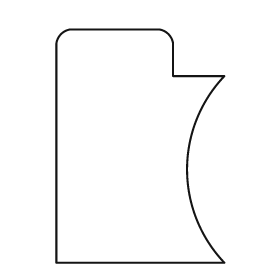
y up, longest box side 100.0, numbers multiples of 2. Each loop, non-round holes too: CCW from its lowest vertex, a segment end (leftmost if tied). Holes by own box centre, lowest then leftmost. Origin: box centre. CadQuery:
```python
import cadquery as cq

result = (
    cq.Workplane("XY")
    .moveTo(-36.0, -50.0)
    .lineTo(36.0, -50.0)
    .threePointArc((20.0, -10.0), (36.0, 30.0))
    .lineTo(14.0, 30.0)
    .lineTo(14.0, 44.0)
    .threePointArc((12.0, 48.0), (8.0, 50.0))
    .lineTo(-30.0, 50.0)
    .threePointArc((-34.0, 48.0), (-36.0, 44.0))
    .close()
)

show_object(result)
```